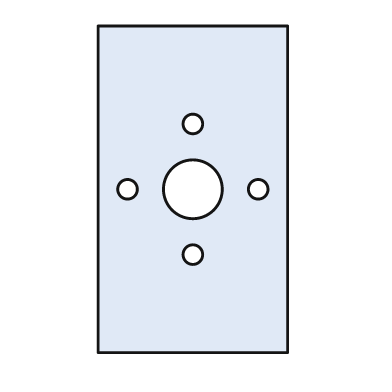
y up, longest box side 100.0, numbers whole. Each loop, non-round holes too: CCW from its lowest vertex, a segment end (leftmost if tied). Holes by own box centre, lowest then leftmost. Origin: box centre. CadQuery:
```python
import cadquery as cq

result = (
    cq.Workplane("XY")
    .moveTo(-29.0, -50.0)
    .lineTo(29.0, -50.0)
    .lineTo(29.0, 50.0)
    .lineTo(-29.0, 50.0)
    .close()
    .moveTo(0.0, -20.0)
    .circle(3.0)
    .moveTo(-20.0, 0.0)
    .circle(3.0)
    .moveTo(0.0, 0.0)
    .circle(9.0)
    .moveTo(20.0, 0.0)
    .circle(3.0)
    .moveTo(0.0, 20.0)
    .circle(3.0)
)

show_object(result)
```